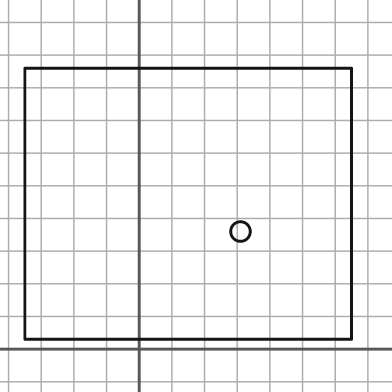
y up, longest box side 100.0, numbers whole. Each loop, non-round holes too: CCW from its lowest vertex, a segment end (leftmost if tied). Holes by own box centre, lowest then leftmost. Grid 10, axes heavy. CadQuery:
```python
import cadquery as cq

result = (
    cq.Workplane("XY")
    .moveTo(-35.0, 3.0)
    .lineTo(65.0, 3.0)
    .lineTo(65.0, 86.0)
    .lineTo(-35.0, 86.0)
    .close()
    .moveTo(31.0, 36.0)
    .circle(3.0)
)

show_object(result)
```